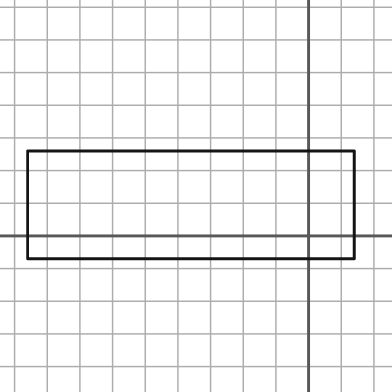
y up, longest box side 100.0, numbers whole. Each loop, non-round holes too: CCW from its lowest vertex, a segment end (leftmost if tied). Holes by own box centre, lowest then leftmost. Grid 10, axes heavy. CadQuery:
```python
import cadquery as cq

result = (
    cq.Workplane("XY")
    .moveTo(-86.0, -7.0)
    .lineTo(14.0, -7.0)
    .lineTo(14.0, 26.0)
    .lineTo(-86.0, 26.0)
    .close()
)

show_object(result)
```